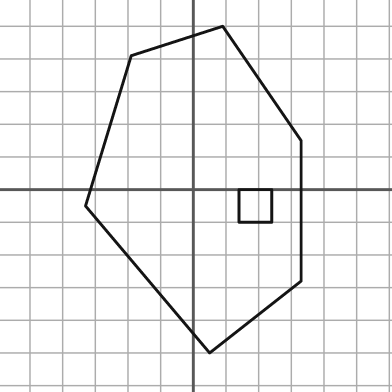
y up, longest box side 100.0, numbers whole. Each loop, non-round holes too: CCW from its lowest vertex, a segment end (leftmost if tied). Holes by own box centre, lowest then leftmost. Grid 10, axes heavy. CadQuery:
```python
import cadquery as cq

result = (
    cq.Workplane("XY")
    .moveTo(5.0, -50.0)
    .lineTo(33.0, -28.0)
    .lineTo(33.0, 15.0)
    .lineTo(9.0, 50.0)
    .lineTo(-19.0, 41.0)
    .lineTo(-33.0, -5.0)
    .close()
    .moveTo(14.0, -10.0)
    .lineTo(24.0, -10.0)
    .lineTo(24.0, 0.0)
    .lineTo(14.0, 0.0)
    .close()
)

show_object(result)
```